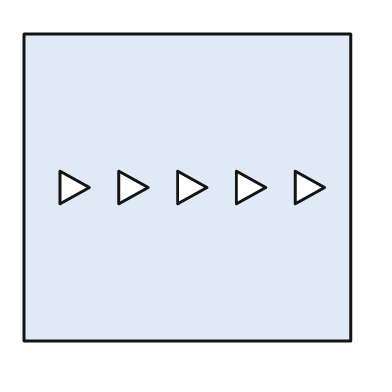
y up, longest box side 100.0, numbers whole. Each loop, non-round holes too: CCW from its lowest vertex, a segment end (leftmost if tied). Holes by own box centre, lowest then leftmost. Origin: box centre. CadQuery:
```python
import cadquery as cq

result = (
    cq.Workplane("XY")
    .moveTo(-50.0, -47.0)
    .lineTo(50.0, -47.0)
    .lineTo(50.0, 47.0)
    .lineTo(-50.0, 47.0)
    .close()
    .moveTo(-39.0, -5.0)
    .lineTo(-30.0, 0.0)
    .lineTo(-39.0, 5.0)
    .close()
    .moveTo(-21.0, -5.0)
    .lineTo(-12.0, 0.0)
    .lineTo(-21.0, 5.0)
    .close()
    .moveTo(-3.0, -5.0)
    .lineTo(6.0, 0.0)
    .lineTo(-3.0, 5.0)
    .close()
    .moveTo(15.0, -5.0)
    .lineTo(24.0, 0.0)
    .lineTo(15.0, 5.0)
    .close()
    .moveTo(33.0, -5.0)
    .lineTo(42.0, 0.0)
    .lineTo(33.0, 5.0)
    .close()
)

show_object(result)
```